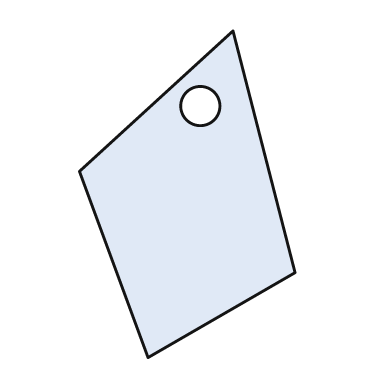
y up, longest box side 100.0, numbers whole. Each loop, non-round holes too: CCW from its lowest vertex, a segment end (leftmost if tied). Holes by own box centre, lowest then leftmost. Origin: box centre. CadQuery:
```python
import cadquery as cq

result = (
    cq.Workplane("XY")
    .moveTo(-12.0, -50.0)
    .lineTo(33.0, -24.0)
    .lineTo(14.0, 50.0)
    .lineTo(-33.0, 7.0)
    .close()
    .moveTo(4.0, 27.0)
    .circle(6.0)
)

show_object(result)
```